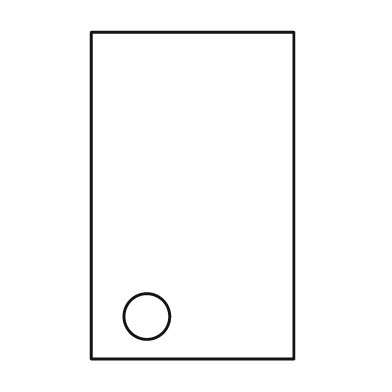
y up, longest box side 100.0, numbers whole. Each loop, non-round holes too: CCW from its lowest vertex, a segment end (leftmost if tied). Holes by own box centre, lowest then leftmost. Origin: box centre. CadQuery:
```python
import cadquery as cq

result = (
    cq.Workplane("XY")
    .moveTo(-31.0, -50.0)
    .lineTo(31.0, -50.0)
    .lineTo(31.0, 50.0)
    .lineTo(-31.0, 50.0)
    .close()
    .moveTo(-14.0, -37.0)
    .circle(7.0)
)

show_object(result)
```